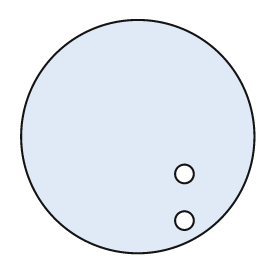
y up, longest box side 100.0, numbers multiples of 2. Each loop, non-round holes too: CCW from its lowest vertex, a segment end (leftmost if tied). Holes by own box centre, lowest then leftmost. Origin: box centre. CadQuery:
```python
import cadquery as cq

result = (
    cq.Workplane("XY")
    .moveTo(0.0, 0.0)
    .circle(50.0)
    .moveTo(20.0, -36.0)
    .circle(4.0)
    .moveTo(20.0, -16.0)
    .circle(4.0)
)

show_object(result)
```